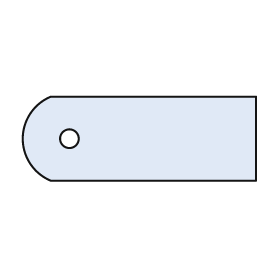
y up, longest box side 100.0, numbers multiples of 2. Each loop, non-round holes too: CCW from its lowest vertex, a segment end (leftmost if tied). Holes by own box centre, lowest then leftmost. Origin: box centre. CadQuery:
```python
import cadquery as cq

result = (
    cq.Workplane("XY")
    .moveTo(-38.0, -18.0)
    .lineTo(50.0, -18.0)
    .lineTo(50.0, 18.0)
    .lineTo(-38.0, 18.0)
    .threePointArc((-50.0, 0.0), (-38.0, -18.0))
    .close()
    .moveTo(-30.0, 0.0)
    .circle(4.0)
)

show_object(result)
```